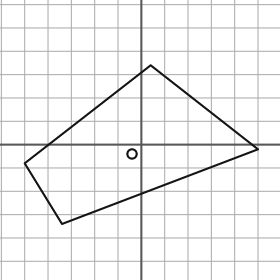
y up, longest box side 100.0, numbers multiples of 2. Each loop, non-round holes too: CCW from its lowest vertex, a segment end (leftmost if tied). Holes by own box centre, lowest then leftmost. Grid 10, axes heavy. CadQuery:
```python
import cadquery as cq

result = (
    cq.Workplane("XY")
    .moveTo(-34.0, -34.0)
    .lineTo(50.0, -2.0)
    .lineTo(4.0, 34.0)
    .lineTo(-50.0, -8.0)
    .close()
    .moveTo(-4.0, -4.0)
    .circle(2.0)
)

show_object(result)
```